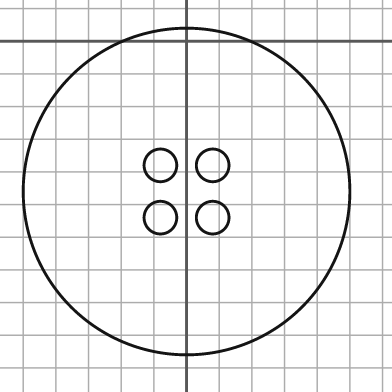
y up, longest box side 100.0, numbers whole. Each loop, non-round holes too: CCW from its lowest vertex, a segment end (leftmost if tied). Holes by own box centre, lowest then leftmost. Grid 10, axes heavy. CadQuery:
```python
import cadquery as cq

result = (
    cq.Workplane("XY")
    .moveTo(0.0, -46.0)
    .circle(50.0)
    .moveTo(-8.0, -54.0)
    .circle(5.0)
    .moveTo(8.0, -54.0)
    .circle(5.0)
    .moveTo(-8.0, -38.0)
    .circle(5.0)
    .moveTo(8.0, -38.0)
    .circle(5.0)
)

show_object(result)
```